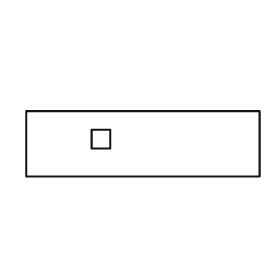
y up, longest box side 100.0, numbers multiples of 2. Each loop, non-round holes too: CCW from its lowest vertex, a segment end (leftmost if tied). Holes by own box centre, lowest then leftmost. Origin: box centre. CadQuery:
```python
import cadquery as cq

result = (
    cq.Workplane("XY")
    .moveTo(-50.0, -14.0)
    .lineTo(50.0, -14.0)
    .lineTo(50.0, 14.0)
    .lineTo(-50.0, 14.0)
    .close()
    .moveTo(-22.0, -2.0)
    .lineTo(-14.0, -2.0)
    .lineTo(-14.0, 6.0)
    .lineTo(-22.0, 6.0)
    .close()
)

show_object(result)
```